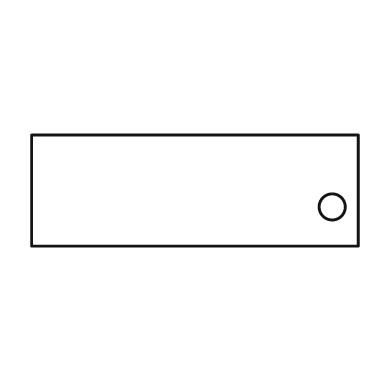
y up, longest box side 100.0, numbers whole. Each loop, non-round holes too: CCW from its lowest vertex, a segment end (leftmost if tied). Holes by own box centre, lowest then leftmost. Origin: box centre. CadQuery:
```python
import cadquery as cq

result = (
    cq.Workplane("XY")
    .moveTo(-50.0, -17.0)
    .lineTo(50.0, -17.0)
    .lineTo(50.0, 17.0)
    .lineTo(-50.0, 17.0)
    .close()
    .moveTo(42.0, -5.0)
    .circle(4.0)
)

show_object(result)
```